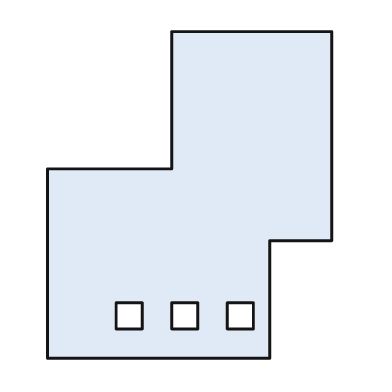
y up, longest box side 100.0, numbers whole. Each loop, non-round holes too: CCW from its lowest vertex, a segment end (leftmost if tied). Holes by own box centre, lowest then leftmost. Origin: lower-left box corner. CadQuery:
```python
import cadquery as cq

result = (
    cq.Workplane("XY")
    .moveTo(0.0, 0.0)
    .lineTo(68.0, 0.0)
    .lineTo(68.0, 36.0)
    .lineTo(87.0, 36.0)
    .lineTo(87.0, 100.0)
    .lineTo(38.0, 100.0)
    .lineTo(38.0, 58.0)
    .lineTo(0.0, 58.0)
    .close()
    .moveTo(21.0, 9.0)
    .lineTo(29.0, 9.0)
    .lineTo(29.0, 17.0)
    .lineTo(21.0, 17.0)
    .close()
    .moveTo(38.0, 9.0)
    .lineTo(46.0, 9.0)
    .lineTo(46.0, 17.0)
    .lineTo(38.0, 17.0)
    .close()
    .moveTo(55.0, 9.0)
    .lineTo(63.0, 9.0)
    .lineTo(63.0, 17.0)
    .lineTo(55.0, 17.0)
    .close()
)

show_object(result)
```